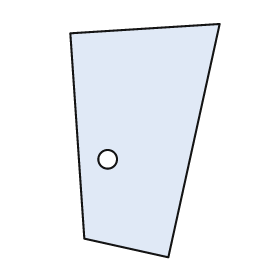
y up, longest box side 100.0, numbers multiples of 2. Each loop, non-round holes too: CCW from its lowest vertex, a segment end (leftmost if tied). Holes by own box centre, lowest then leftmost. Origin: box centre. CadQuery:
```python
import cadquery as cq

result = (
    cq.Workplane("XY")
    .moveTo(10.0, -50.0)
    .lineTo(32.0, 50.0)
    .lineTo(-32.0, 46.0)
    .lineTo(-26.0, -42.0)
    .close()
    .moveTo(-16.0, -8.0)
    .circle(4.0)
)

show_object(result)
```